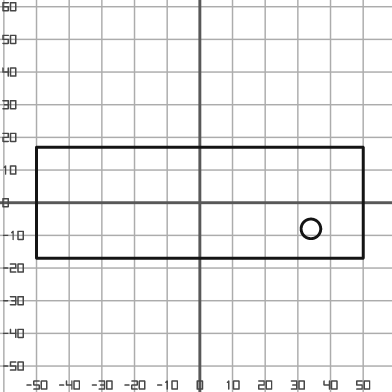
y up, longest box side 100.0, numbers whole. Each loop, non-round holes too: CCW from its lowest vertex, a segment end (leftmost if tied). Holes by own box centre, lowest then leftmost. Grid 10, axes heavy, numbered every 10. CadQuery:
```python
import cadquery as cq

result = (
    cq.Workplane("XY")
    .moveTo(-50.0, -17.0)
    .lineTo(50.0, -17.0)
    .lineTo(50.0, 17.0)
    .lineTo(-50.0, 17.0)
    .close()
    .moveTo(34.0, -8.0)
    .circle(3.0)
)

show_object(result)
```